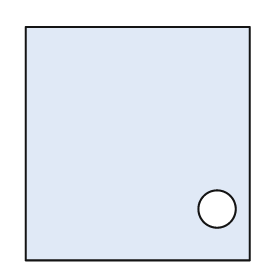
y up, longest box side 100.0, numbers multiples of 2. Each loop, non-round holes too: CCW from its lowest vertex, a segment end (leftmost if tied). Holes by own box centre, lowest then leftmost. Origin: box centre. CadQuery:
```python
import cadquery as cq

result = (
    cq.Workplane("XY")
    .moveTo(-48.0, -50.0)
    .lineTo(48.0, -50.0)
    .lineTo(48.0, 50.0)
    .lineTo(-48.0, 50.0)
    .close()
    .moveTo(34.0, -28.0)
    .circle(8.0)
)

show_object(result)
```